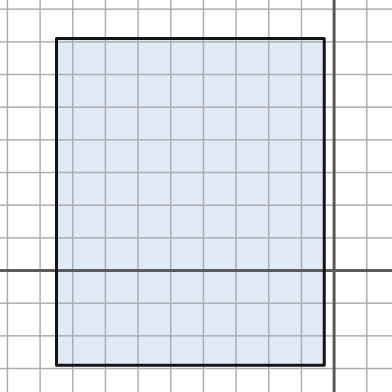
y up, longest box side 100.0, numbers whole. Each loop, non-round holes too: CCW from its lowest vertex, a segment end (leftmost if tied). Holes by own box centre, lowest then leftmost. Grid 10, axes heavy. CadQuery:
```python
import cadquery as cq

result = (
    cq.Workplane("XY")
    .moveTo(-85.0, -29.0)
    .lineTo(-3.0, -29.0)
    .lineTo(-3.0, 71.0)
    .lineTo(-85.0, 71.0)
    .close()
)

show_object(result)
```